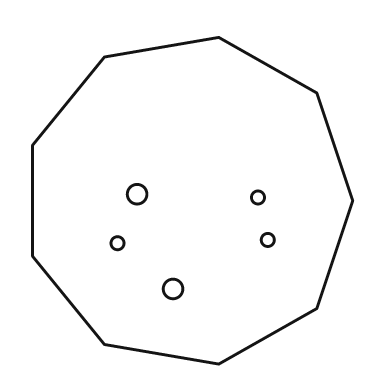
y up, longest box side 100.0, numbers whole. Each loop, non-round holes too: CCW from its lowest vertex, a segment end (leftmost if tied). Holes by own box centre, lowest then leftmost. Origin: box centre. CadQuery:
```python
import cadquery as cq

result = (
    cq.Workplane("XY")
    .moveTo(8.0, -50.0)
    .lineTo(38.0, -33.0)
    .lineTo(49.0, 0.0)
    .lineTo(38.0, 33.0)
    .lineTo(8.0, 50.0)
    .lineTo(-27.0, 44.0)
    .lineTo(-49.0, 17.0)
    .lineTo(-49.0, -17.0)
    .lineTo(-27.0, -44.0)
    .close()
    .moveTo(-6.0, -27.0)
    .circle(3.0)
    .moveTo(-23.0, -13.0)
    .circle(2.0)
    .moveTo(23.0, -12.0)
    .circle(2.0)
    .moveTo(20.0, 1.0)
    .circle(2.0)
    .moveTo(-17.0, 2.0)
    .circle(3.0)
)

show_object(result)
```